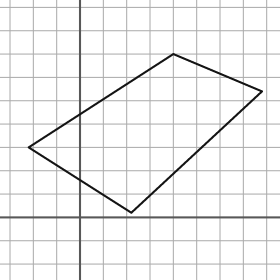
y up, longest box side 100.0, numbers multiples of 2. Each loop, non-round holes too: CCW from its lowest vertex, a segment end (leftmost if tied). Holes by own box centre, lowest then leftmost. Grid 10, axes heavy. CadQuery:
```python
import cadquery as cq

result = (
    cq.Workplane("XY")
    .moveTo(22.0, 2.0)
    .lineTo(78.0, 54.0)
    .lineTo(40.0, 70.0)
    .lineTo(-22.0, 30.0)
    .close()
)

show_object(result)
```